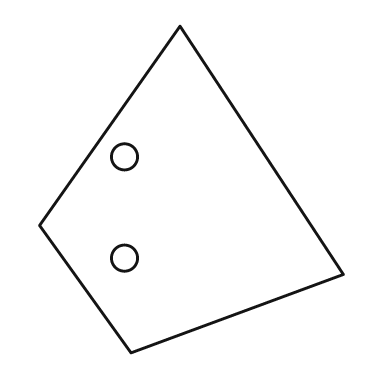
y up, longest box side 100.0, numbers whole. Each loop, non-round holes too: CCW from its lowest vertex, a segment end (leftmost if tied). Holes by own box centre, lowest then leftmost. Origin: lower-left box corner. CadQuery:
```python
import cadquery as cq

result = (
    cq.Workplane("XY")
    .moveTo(28.0, 0.0)
    .lineTo(93.0, 24.0)
    .lineTo(43.0, 100.0)
    .lineTo(0.0, 39.0)
    .close()
    .moveTo(26.0, 29.0)
    .circle(4.0)
    .moveTo(26.0, 60.0)
    .circle(4.0)
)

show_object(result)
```